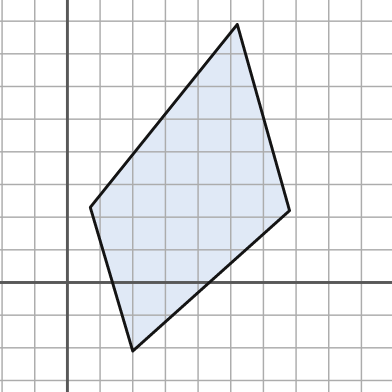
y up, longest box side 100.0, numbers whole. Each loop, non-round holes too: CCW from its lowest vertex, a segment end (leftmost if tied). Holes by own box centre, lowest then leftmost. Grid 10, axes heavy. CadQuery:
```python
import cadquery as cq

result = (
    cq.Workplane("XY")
    .moveTo(20.0, -21.0)
    .lineTo(68.0, 22.0)
    .lineTo(52.0, 79.0)
    .lineTo(7.0, 23.0)
    .close()
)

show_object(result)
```